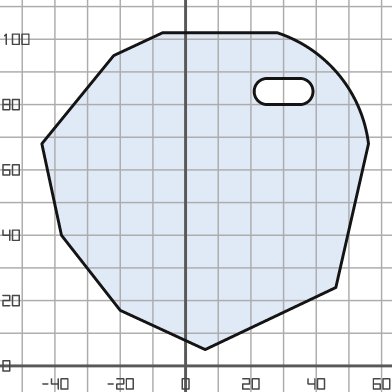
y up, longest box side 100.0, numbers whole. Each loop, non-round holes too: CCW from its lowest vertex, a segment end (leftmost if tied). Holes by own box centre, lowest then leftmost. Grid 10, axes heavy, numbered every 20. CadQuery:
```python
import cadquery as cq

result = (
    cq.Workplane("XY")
    .moveTo(6.0, 5.0)
    .lineTo(46.0, 24.0)
    .lineTo(56.0, 68.0)
    .threePointArc((47.0, 89.0), (28.0, 102.0))
    .lineTo(-7.0, 102.0)
    .lineTo(-22.0, 95.0)
    .lineTo(-44.0, 68.0)
    .lineTo(-38.0, 40.0)
    .lineTo(-20.0, 17.0)
    .close()
    .moveTo(25.0, 80.0)
    .lineTo(35.0, 80.0)
    .threePointArc((39.0, 84.0), (35.0, 88.0))
    .lineTo(25.0, 88.0)
    .threePointArc((21.0, 84.0), (25.0, 80.0))
    .close()
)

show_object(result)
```